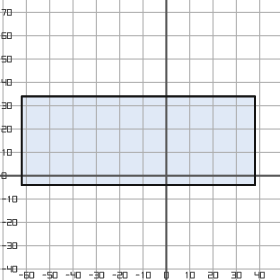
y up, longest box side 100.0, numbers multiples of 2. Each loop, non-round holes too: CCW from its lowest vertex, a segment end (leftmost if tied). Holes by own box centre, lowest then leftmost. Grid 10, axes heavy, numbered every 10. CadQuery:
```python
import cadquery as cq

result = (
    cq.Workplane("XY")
    .moveTo(-62.0, -4.0)
    .lineTo(38.0, -4.0)
    .lineTo(38.0, 34.0)
    .lineTo(-62.0, 34.0)
    .close()
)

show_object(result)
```